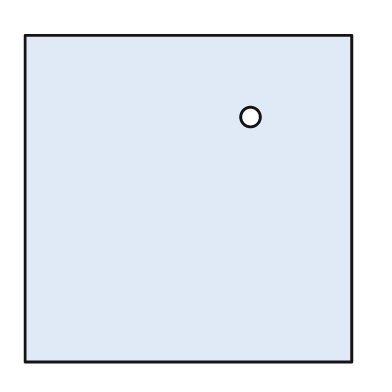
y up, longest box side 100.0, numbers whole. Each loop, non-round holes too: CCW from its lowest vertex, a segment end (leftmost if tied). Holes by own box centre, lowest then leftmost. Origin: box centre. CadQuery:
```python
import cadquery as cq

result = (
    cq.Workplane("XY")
    .moveTo(-50.0, -50.0)
    .lineTo(50.0, -50.0)
    .lineTo(50.0, 50.0)
    .lineTo(-50.0, 50.0)
    .close()
    .moveTo(19.0, 25.0)
    .circle(3.0)
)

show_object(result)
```